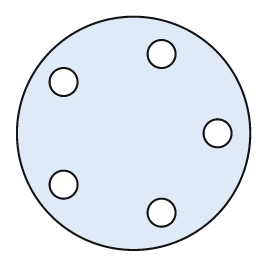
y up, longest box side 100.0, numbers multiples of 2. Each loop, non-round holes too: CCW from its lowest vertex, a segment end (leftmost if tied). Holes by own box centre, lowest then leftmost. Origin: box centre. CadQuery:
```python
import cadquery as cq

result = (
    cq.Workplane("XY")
    .moveTo(0.0, 0.0)
    .circle(50.0)
    .moveTo(12.0, -34.0)
    .circle(6.0)
    .moveTo(-30.0, -22.0)
    .circle(6.0)
    .moveTo(36.0, 0.0)
    .circle(6.0)
    .moveTo(-30.0, 22.0)
    .circle(6.0)
    .moveTo(12.0, 34.0)
    .circle(6.0)
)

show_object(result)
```